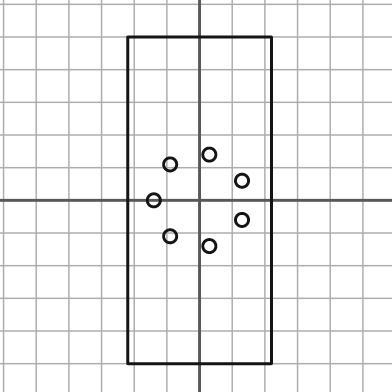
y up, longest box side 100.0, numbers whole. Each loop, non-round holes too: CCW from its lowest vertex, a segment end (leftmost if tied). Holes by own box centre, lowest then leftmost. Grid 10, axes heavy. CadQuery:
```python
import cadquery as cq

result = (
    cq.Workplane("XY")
    .moveTo(-22.0, -50.0)
    .lineTo(22.0, -50.0)
    .lineTo(22.0, 50.0)
    .lineTo(-22.0, 50.0)
    .close()
    .moveTo(3.0, -14.0)
    .circle(2.0)
    .moveTo(-9.0, -11.0)
    .circle(2.0)
    .moveTo(13.0, -6.0)
    .circle(2.0)
    .moveTo(-14.0, 0.0)
    .circle(2.0)
    .moveTo(13.0, 6.0)
    .circle(2.0)
    .moveTo(-9.0, 11.0)
    .circle(2.0)
    .moveTo(3.0, 14.0)
    .circle(2.0)
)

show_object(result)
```